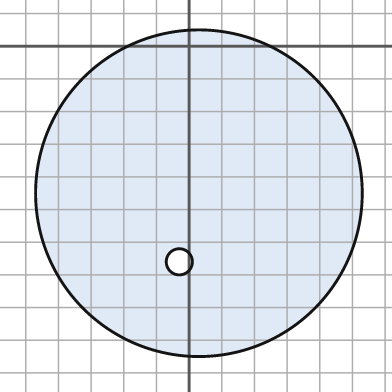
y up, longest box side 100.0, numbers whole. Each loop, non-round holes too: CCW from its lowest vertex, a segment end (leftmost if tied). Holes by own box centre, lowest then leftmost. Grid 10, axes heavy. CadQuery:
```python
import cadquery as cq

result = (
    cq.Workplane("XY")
    .moveTo(3.0, -45.0)
    .circle(50.0)
    .moveTo(-3.0, -66.0)
    .circle(4.0)
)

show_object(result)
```